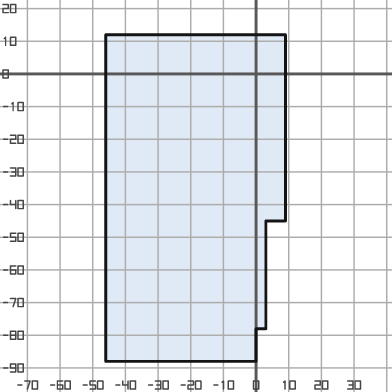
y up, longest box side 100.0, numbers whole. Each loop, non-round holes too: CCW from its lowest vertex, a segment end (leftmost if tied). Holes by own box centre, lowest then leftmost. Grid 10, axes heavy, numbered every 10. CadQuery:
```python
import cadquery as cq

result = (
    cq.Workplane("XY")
    .moveTo(-46.0, -88.0)
    .lineTo(0.0, -88.0)
    .lineTo(0.0, -78.0)
    .lineTo(3.0, -78.0)
    .lineTo(3.0, -45.0)
    .lineTo(9.0, -45.0)
    .lineTo(9.0, 12.0)
    .lineTo(-46.0, 12.0)
    .close()
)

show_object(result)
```